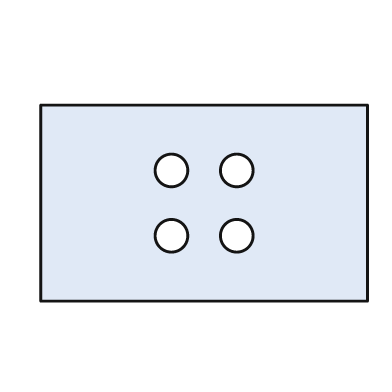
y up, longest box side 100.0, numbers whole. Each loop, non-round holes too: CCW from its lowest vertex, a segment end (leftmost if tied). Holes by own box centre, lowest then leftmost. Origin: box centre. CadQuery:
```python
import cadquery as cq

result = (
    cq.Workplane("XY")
    .moveTo(-50.0, -30.0)
    .lineTo(50.0, -30.0)
    .lineTo(50.0, 30.0)
    .lineTo(-50.0, 30.0)
    .close()
    .moveTo(-10.0, -10.0)
    .circle(5.0)
    .moveTo(10.0, -10.0)
    .circle(5.0)
    .moveTo(-10.0, 10.0)
    .circle(5.0)
    .moveTo(10.0, 10.0)
    .circle(5.0)
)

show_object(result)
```